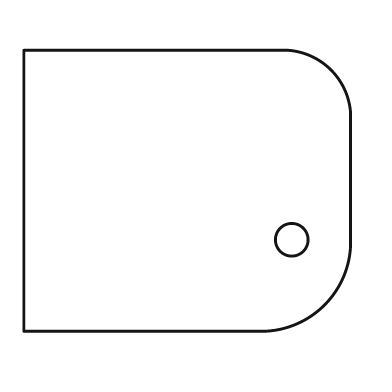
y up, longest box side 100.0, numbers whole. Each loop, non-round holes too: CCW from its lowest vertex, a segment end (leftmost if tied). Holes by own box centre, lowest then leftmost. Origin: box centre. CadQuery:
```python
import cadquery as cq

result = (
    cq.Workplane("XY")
    .moveTo(-50.0, -43.0)
    .lineTo(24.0, -43.0)
    .threePointArc((42.0, -35.0), (50.0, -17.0))
    .lineTo(50.0, 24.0)
    .threePointArc((44.0, 37.0), (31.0, 43.0))
    .lineTo(-50.0, 43.0)
    .close()
    .moveTo(32.0, -15.0)
    .circle(5.0)
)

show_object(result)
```